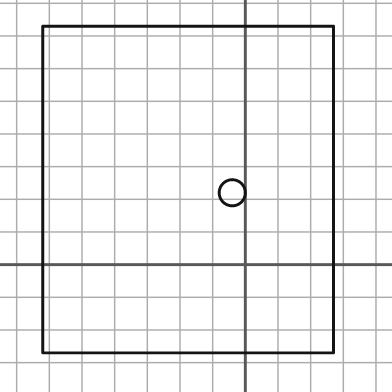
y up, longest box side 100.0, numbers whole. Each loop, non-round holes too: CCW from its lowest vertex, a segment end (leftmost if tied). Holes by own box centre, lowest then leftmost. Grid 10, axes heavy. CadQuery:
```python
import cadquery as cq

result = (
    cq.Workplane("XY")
    .moveTo(-62.0, -27.0)
    .lineTo(27.0, -27.0)
    .lineTo(27.0, 73.0)
    .lineTo(-62.0, 73.0)
    .close()
    .moveTo(-4.0, 22.0)
    .circle(4.0)
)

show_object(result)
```